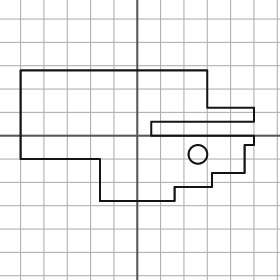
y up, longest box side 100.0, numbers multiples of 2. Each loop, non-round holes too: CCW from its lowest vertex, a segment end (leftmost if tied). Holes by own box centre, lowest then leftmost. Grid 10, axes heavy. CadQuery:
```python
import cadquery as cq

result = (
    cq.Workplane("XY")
    .moveTo(-16.0, -28.0)
    .lineTo(16.0, -28.0)
    .lineTo(16.0, -22.0)
    .lineTo(32.0, -22.0)
    .lineTo(32.0, -16.0)
    .lineTo(46.0, -16.0)
    .lineTo(46.0, -4.0)
    .lineTo(50.0, -4.0)
    .lineTo(50.0, 0.0)
    .lineTo(6.0, 0.0)
    .lineTo(6.0, 6.0)
    .lineTo(50.0, 6.0)
    .lineTo(50.0, 12.0)
    .lineTo(30.0, 12.0)
    .lineTo(30.0, 28.0)
    .lineTo(-50.0, 28.0)
    .lineTo(-50.0, -10.0)
    .lineTo(-16.0, -10.0)
    .close()
    .moveTo(26.0, -8.0)
    .circle(4.0)
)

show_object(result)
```